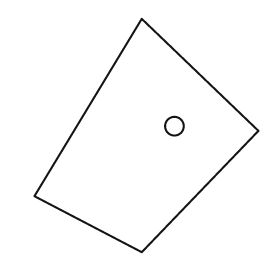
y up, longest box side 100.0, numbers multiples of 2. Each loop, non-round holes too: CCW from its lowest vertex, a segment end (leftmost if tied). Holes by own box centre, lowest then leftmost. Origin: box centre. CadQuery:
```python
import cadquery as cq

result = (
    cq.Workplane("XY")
    .moveTo(-2.0, -50.0)
    .lineTo(48.0, 2.0)
    .lineTo(-2.0, 50.0)
    .lineTo(-48.0, -26.0)
    .close()
    .moveTo(12.0, 4.0)
    .circle(4.0)
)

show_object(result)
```